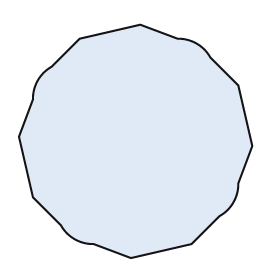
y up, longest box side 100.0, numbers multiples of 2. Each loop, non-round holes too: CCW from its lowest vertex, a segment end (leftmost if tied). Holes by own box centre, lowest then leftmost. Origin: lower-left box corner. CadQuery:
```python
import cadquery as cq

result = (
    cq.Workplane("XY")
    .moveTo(48.0, 0.0)
    .lineTo(74.0, 6.0)
    .lineTo(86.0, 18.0)
    .threePointArc((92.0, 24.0), (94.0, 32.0))
    .lineTo(100.0, 48.0)
    .lineTo(94.0, 74.0)
    .lineTo(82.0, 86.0)
    .threePointArc((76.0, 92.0), (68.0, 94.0))
    .lineTo(52.0, 100.0)
    .lineTo(26.0, 94.0)
    .lineTo(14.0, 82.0)
    .threePointArc((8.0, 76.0), (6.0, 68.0))
    .lineTo(0.0, 52.0)
    .lineTo(6.0, 26.0)
    .lineTo(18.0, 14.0)
    .threePointArc((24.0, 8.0), (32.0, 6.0))
    .close()
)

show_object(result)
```